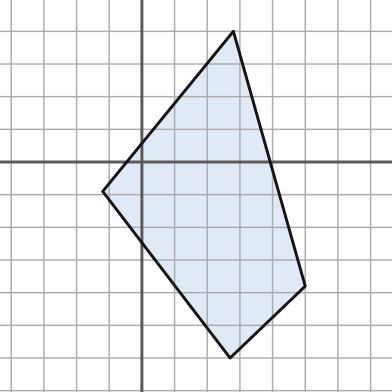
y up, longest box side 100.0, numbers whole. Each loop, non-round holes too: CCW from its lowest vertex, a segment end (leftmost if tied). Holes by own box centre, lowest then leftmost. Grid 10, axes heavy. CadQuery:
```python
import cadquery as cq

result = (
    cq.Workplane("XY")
    .moveTo(27.0, -60.0)
    .lineTo(50.0, -38.0)
    .lineTo(28.0, 40.0)
    .lineTo(-12.0, -9.0)
    .close()
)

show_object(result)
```